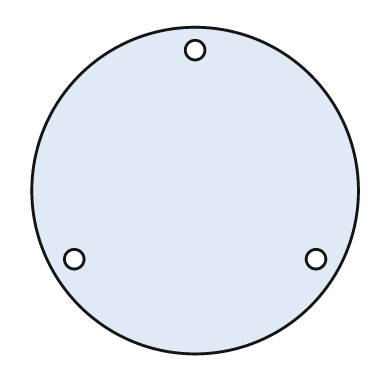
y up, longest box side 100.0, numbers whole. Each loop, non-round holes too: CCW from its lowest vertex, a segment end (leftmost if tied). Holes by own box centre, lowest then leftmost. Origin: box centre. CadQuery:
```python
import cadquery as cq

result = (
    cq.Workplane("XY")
    .moveTo(0.0, 0.0)
    .circle(50.0)
    .moveTo(-37.0, -21.0)
    .circle(3.0)
    .moveTo(37.0, -21.0)
    .circle(3.0)
    .moveTo(0.0, 43.0)
    .circle(3.0)
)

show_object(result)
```